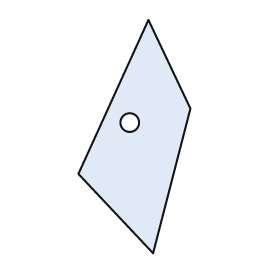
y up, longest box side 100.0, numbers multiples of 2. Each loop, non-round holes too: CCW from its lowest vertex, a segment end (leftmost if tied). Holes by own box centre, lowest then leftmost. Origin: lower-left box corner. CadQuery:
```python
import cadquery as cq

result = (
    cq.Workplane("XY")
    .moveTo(32.0, 0.0)
    .lineTo(48.0, 62.0)
    .lineTo(30.0, 100.0)
    .lineTo(0.0, 34.0)
    .close()
    .moveTo(22.0, 56.0)
    .circle(4.0)
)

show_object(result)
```